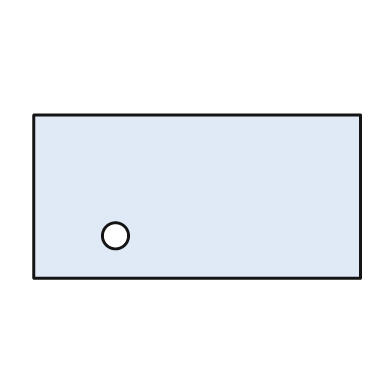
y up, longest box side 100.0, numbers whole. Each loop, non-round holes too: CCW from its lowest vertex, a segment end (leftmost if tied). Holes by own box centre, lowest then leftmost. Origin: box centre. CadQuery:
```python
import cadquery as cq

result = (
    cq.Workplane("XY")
    .moveTo(-50.0, -25.0)
    .lineTo(50.0, -25.0)
    .lineTo(50.0, 25.0)
    .lineTo(-50.0, 25.0)
    .close()
    .moveTo(-25.0, -12.0)
    .circle(4.0)
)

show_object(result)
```